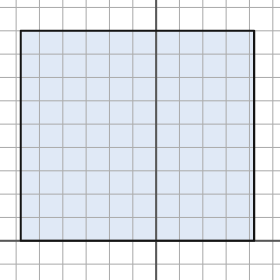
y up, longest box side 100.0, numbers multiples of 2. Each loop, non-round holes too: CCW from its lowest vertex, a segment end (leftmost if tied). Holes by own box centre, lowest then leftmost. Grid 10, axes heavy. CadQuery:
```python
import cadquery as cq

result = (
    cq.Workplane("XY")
    .moveTo(-58.0, 0.0)
    .lineTo(42.0, 0.0)
    .lineTo(42.0, 90.0)
    .lineTo(-58.0, 90.0)
    .close()
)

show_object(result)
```